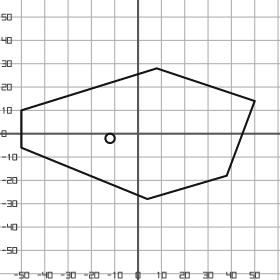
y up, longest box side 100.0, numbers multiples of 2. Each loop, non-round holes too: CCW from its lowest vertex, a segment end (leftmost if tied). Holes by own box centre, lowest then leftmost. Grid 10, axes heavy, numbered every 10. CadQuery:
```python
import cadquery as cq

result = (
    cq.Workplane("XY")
    .moveTo(4.0, -28.0)
    .lineTo(38.0, -18.0)
    .lineTo(50.0, 14.0)
    .lineTo(8.0, 28.0)
    .lineTo(-50.0, 10.0)
    .lineTo(-50.0, -6.0)
    .close()
    .moveTo(-12.0, -2.0)
    .circle(2.0)
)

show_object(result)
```